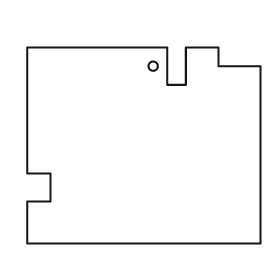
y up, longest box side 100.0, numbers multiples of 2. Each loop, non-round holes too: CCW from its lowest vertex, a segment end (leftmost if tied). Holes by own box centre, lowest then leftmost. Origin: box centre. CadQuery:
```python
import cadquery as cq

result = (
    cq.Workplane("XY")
    .moveTo(-50.0, -42.0)
    .lineTo(50.0, -42.0)
    .lineTo(50.0, 34.0)
    .lineTo(32.0, 34.0)
    .lineTo(32.0, 42.0)
    .lineTo(18.0, 42.0)
    .lineTo(18.0, 26.0)
    .lineTo(10.0, 26.0)
    .lineTo(10.0, 42.0)
    .lineTo(-50.0, 42.0)
    .lineTo(-50.0, -12.0)
    .lineTo(-40.0, -12.0)
    .lineTo(-40.0, -24.0)
    .lineTo(-50.0, -24.0)
    .close()
    .moveTo(4.0, 34.0)
    .circle(2.0)
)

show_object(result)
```